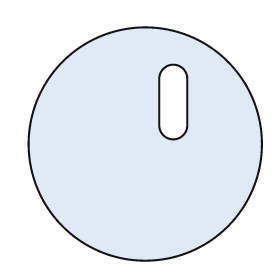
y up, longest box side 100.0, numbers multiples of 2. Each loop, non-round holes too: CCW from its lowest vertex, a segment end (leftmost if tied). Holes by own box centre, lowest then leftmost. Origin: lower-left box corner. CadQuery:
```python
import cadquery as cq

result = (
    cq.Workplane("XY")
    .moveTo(50.0, 50.0)
    .circle(50.0)
    .moveTo(56.0, 58.0)
    .threePointArc((62.0, 52.0), (68.0, 58.0))
    .lineTo(68.0, 78.0)
    .threePointArc((62.0, 84.0), (56.0, 78.0))
    .close()
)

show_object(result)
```